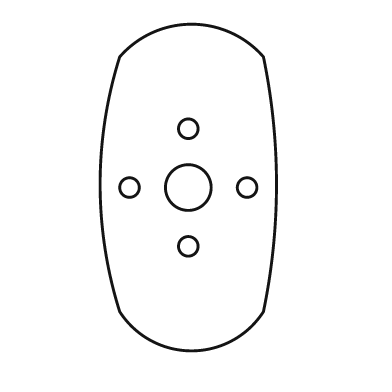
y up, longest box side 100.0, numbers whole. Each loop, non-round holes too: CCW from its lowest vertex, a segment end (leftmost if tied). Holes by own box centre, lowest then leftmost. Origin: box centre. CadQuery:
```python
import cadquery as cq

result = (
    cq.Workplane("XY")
    .moveTo(-21.0, -38.0)
    .threePointArc((1.0, -50.0), (23.0, -38.0))
    .threePointArc((27.0, 1.0), (23.0, 40.0))
    .threePointArc((1.0, 50.0), (-21.0, 40.0))
    .threePointArc((-27.0, 1.0), (-21.0, -38.0))
    .close()
    .moveTo(0.0, -18.0)
    .circle(3.0)
    .moveTo(-18.0, 0.0)
    .circle(3.0)
    .moveTo(0.0, 0.0)
    .circle(7.0)
    .moveTo(18.0, 0.0)
    .circle(3.0)
    .moveTo(0.0, 18.0)
    .circle(3.0)
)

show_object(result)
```